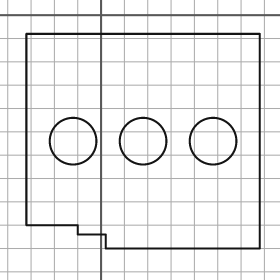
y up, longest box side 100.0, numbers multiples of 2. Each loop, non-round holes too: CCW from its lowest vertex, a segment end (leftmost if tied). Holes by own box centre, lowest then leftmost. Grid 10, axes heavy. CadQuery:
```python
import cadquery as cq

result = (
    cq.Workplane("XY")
    .moveTo(2.0, -100.0)
    .lineTo(68.0, -100.0)
    .lineTo(68.0, -8.0)
    .lineTo(-32.0, -8.0)
    .lineTo(-32.0, -90.0)
    .lineTo(-10.0, -90.0)
    .lineTo(-10.0, -94.0)
    .lineTo(2.0, -94.0)
    .close()
    .moveTo(-12.0, -54.0)
    .circle(10.0)
    .moveTo(18.0, -54.0)
    .circle(10.0)
    .moveTo(48.0, -54.0)
    .circle(10.0)
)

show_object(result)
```